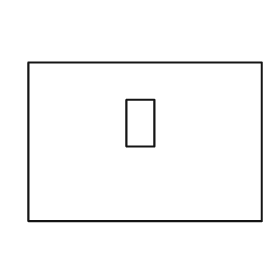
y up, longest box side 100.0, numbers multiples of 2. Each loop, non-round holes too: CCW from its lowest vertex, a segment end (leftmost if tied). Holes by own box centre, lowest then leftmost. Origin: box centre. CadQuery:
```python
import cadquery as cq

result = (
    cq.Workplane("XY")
    .moveTo(-50.0, -34.0)
    .lineTo(50.0, -34.0)
    .lineTo(50.0, 34.0)
    .lineTo(-50.0, 34.0)
    .close()
    .moveTo(-8.0, -2.0)
    .lineTo(4.0, -2.0)
    .lineTo(4.0, 18.0)
    .lineTo(-8.0, 18.0)
    .close()
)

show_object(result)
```